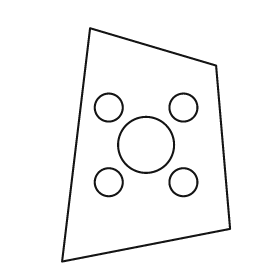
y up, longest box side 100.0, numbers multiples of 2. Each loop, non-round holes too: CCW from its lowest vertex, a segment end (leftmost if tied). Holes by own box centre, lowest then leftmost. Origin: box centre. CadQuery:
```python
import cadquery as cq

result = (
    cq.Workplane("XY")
    .moveTo(-36.0, -50.0)
    .lineTo(36.0, -36.0)
    .lineTo(30.0, 34.0)
    .lineTo(-24.0, 50.0)
    .close()
    .moveTo(-16.0, -16.0)
    .circle(6.0)
    .moveTo(16.0, -16.0)
    .circle(6.0)
    .moveTo(0.0, 0.0)
    .circle(12.0)
    .moveTo(-16.0, 16.0)
    .circle(6.0)
    .moveTo(16.0, 16.0)
    .circle(6.0)
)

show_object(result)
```